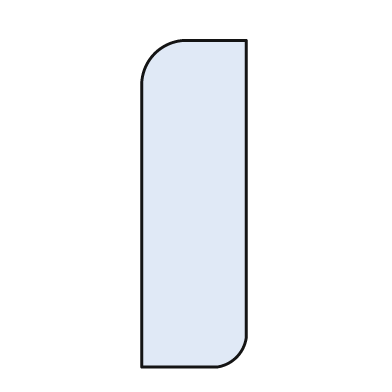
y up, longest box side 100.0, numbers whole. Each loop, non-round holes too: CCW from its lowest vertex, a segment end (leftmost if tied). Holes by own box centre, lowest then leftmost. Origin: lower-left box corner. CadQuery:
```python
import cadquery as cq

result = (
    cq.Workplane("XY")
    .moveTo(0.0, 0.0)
    .lineTo(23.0, 0.0)
    .threePointArc((29.0, 3.0), (32.0, 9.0))
    .lineTo(32.0, 100.0)
    .lineTo(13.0, 100.0)
    .threePointArc((4.0, 96.0), (0.0, 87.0))
    .close()
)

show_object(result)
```